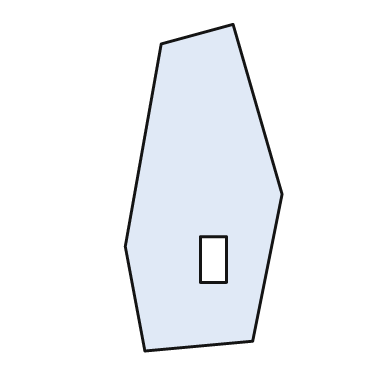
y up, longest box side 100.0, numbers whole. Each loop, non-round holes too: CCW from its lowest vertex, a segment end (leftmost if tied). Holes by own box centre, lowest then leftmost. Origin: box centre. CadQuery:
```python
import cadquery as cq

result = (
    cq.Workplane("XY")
    .moveTo(-18.0, -50.0)
    .lineTo(15.0, -47.0)
    .lineTo(24.0, -2.0)
    .lineTo(9.0, 50.0)
    .lineTo(-13.0, 44.0)
    .lineTo(-24.0, -18.0)
    .close()
    .moveTo(-1.0, -29.0)
    .lineTo(7.0, -29.0)
    .lineTo(7.0, -15.0)
    .lineTo(-1.0, -15.0)
    .close()
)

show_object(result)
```